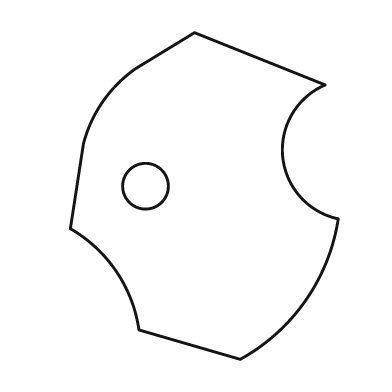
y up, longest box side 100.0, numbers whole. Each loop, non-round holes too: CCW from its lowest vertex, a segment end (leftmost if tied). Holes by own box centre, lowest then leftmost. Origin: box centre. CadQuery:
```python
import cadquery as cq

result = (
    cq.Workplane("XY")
    .moveTo(11.0, -50.0)
    .threePointArc((31.0, -32.0), (41.0, -7.0))
    .threePointArc((24.0, 12.0), (37.0, 34.0))
    .lineTo(-3.0, 50.0)
    .lineTo(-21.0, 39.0)
    .threePointArc((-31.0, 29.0), (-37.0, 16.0))
    .lineTo(-41.0, -10.0)
    .threePointArc((-27.0, -23.0), (-20.0, -41.0))
    .close()
    .moveTo(-18.0, 3.0)
    .circle(7.0)
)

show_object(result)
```